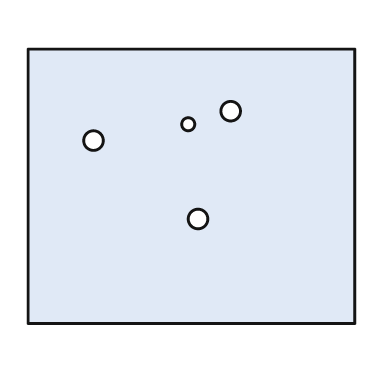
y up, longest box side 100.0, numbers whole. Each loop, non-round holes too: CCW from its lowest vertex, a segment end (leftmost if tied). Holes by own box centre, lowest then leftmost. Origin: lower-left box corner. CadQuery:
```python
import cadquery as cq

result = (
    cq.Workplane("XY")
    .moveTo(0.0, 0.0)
    .lineTo(100.0, 0.0)
    .lineTo(100.0, 84.0)
    .lineTo(0.0, 84.0)
    .close()
    .moveTo(52.0, 32.0)
    .circle(3.0)
    .moveTo(20.0, 56.0)
    .circle(3.0)
    .moveTo(49.0, 61.0)
    .circle(2.0)
    .moveTo(62.0, 65.0)
    .circle(3.0)
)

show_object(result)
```